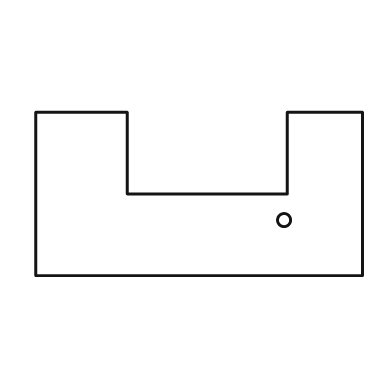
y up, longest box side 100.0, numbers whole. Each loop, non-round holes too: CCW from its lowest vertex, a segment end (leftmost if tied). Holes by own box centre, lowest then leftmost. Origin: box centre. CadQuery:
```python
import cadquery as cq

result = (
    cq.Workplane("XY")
    .moveTo(-50.0, -25.0)
    .lineTo(50.0, -25.0)
    .lineTo(50.0, 25.0)
    .lineTo(27.0, 25.0)
    .lineTo(27.0, 0.0)
    .lineTo(-22.0, 0.0)
    .lineTo(-22.0, 25.0)
    .lineTo(-50.0, 25.0)
    .close()
    .moveTo(26.0, -8.0)
    .circle(2.0)
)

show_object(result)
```